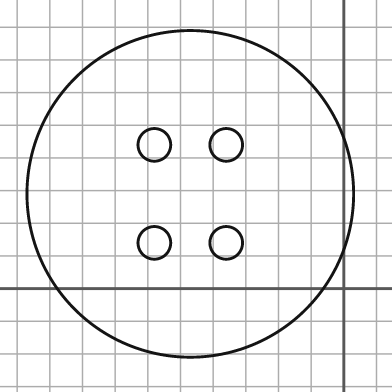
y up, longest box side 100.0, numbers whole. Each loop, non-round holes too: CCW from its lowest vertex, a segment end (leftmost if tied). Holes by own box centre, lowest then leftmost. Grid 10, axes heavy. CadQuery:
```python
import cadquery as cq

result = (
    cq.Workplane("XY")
    .moveTo(-47.0, 29.0)
    .circle(50.0)
    .moveTo(-58.0, 14.0)
    .circle(5.0)
    .moveTo(-36.0, 14.0)
    .circle(5.0)
    .moveTo(-58.0, 44.0)
    .circle(5.0)
    .moveTo(-36.0, 44.0)
    .circle(5.0)
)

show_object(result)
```